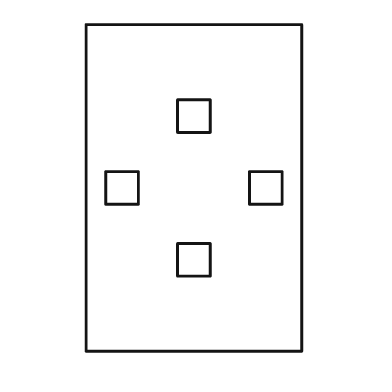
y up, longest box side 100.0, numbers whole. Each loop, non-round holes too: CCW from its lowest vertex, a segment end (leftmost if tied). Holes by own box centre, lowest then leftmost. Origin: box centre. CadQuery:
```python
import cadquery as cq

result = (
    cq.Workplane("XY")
    .moveTo(-33.0, -50.0)
    .lineTo(33.0, -50.0)
    .lineTo(33.0, 50.0)
    .lineTo(-33.0, 50.0)
    .close()
    .moveTo(-5.0, -27.0)
    .lineTo(5.0, -27.0)
    .lineTo(5.0, -17.0)
    .lineTo(-5.0, -17.0)
    .close()
    .moveTo(-27.0, -5.0)
    .lineTo(-17.0, -5.0)
    .lineTo(-17.0, 5.0)
    .lineTo(-27.0, 5.0)
    .close()
    .moveTo(17.0, -5.0)
    .lineTo(27.0, -5.0)
    .lineTo(27.0, 5.0)
    .lineTo(17.0, 5.0)
    .close()
    .moveTo(-5.0, 17.0)
    .lineTo(5.0, 17.0)
    .lineTo(5.0, 27.0)
    .lineTo(-5.0, 27.0)
    .close()
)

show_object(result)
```